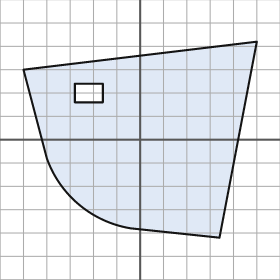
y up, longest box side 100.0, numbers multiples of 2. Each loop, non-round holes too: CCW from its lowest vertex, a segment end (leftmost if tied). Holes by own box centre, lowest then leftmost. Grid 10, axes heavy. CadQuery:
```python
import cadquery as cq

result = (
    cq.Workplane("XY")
    .moveTo(34.0, -42.0)
    .lineTo(50.0, 42.0)
    .lineTo(-50.0, 30.0)
    .lineTo(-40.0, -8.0)
    .threePointArc((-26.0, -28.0), (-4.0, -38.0))
    .close()
    .moveTo(-28.0, 16.0)
    .lineTo(-16.0, 16.0)
    .lineTo(-16.0, 24.0)
    .lineTo(-28.0, 24.0)
    .close()
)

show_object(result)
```